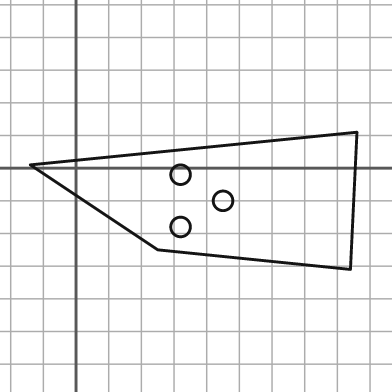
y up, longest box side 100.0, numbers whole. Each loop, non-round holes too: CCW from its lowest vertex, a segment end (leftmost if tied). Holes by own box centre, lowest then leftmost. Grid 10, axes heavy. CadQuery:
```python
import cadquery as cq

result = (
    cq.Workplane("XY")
    .moveTo(84.0, -31.0)
    .lineTo(86.0, 11.0)
    .lineTo(-14.0, 1.0)
    .lineTo(25.0, -25.0)
    .close()
    .moveTo(32.0, -18.0)
    .circle(3.0)
    .moveTo(45.0, -10.0)
    .circle(3.0)
    .moveTo(32.0, -2.0)
    .circle(3.0)
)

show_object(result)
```